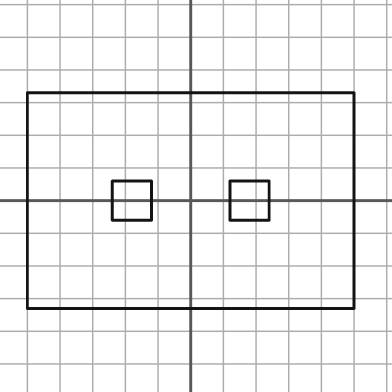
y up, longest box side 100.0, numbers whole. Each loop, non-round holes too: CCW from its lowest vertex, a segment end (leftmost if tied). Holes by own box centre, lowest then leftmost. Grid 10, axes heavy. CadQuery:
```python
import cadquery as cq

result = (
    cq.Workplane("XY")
    .moveTo(-50.0, -33.0)
    .lineTo(50.0, -33.0)
    .lineTo(50.0, 33.0)
    .lineTo(-50.0, 33.0)
    .close()
    .moveTo(-24.0, -6.0)
    .lineTo(-12.0, -6.0)
    .lineTo(-12.0, 6.0)
    .lineTo(-24.0, 6.0)
    .close()
    .moveTo(12.0, -6.0)
    .lineTo(24.0, -6.0)
    .lineTo(24.0, 6.0)
    .lineTo(12.0, 6.0)
    .close()
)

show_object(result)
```